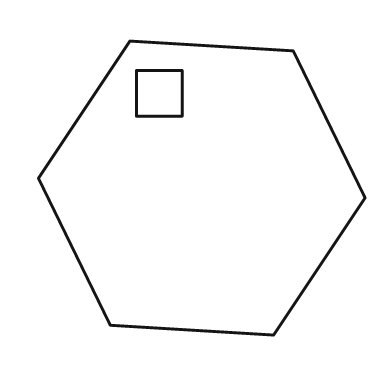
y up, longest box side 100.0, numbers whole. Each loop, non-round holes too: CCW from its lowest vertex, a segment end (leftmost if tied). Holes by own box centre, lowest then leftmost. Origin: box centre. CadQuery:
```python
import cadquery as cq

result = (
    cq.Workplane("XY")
    .moveTo(22.0, -45.0)
    .lineTo(50.0, -3.0)
    .lineTo(28.0, 42.0)
    .lineTo(-22.0, 45.0)
    .lineTo(-50.0, 3.0)
    .lineTo(-28.0, -42.0)
    .close()
    .moveTo(-20.0, 22.0)
    .lineTo(-6.0, 22.0)
    .lineTo(-6.0, 36.0)
    .lineTo(-20.0, 36.0)
    .close()
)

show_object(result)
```